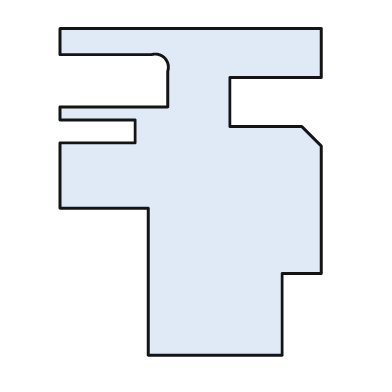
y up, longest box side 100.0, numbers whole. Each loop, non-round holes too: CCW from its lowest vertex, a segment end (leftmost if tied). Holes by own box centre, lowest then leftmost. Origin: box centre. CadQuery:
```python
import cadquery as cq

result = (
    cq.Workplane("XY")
    .moveTo(-13.0, -50.0)
    .lineTo(28.0, -50.0)
    .lineTo(28.0, -25.0)
    .lineTo(40.0, -25.0)
    .lineTo(40.0, 14.0)
    .lineTo(34.0, 20.0)
    .lineTo(12.0, 20.0)
    .lineTo(12.0, 35.0)
    .lineTo(40.0, 35.0)
    .lineTo(40.0, 50.0)
    .lineTo(-40.0, 50.0)
    .lineTo(-40.0, 42.0)
    .lineTo(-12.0, 42.0)
    .threePointArc((-8.0, 41.0), (-7.0, 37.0))
    .lineTo(-7.0, 26.0)
    .lineTo(-40.0, 26.0)
    .lineTo(-40.0, 22.0)
    .lineTo(-17.0, 22.0)
    .lineTo(-17.0, 15.0)
    .lineTo(-40.0, 15.0)
    .lineTo(-40.0, -5.0)
    .lineTo(-13.0, -5.0)
    .close()
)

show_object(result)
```